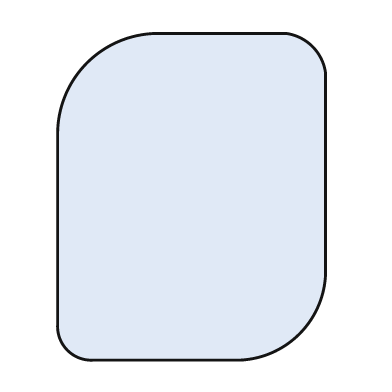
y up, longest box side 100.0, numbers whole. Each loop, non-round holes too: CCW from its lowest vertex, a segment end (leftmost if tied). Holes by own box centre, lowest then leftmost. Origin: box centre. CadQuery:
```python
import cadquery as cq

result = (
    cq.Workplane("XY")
    .moveTo(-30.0, -50.0)
    .lineTo(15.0, -50.0)
    .threePointArc((33.0, -42.0), (41.0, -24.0))
    .lineTo(41.0, 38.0)
    .threePointArc((37.0, 46.0), (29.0, 50.0))
    .lineTo(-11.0, 50.0)
    .threePointArc((-32.0, 41.0), (-41.0, 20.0))
    .lineTo(-41.0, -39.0)
    .threePointArc((-38.0, -47.0), (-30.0, -50.0))
    .close()
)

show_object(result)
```